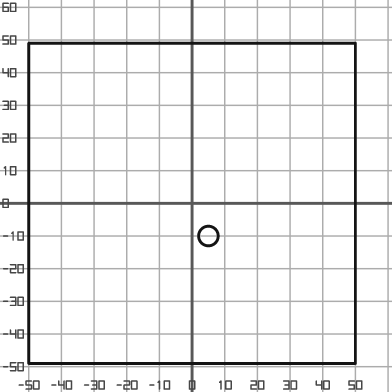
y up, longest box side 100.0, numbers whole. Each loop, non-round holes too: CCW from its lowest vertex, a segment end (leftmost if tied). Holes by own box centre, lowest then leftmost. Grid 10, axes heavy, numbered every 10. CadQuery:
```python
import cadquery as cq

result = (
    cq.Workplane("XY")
    .moveTo(-50.0, -49.0)
    .lineTo(50.0, -49.0)
    .lineTo(50.0, 49.0)
    .lineTo(-50.0, 49.0)
    .close()
    .moveTo(5.0, -10.0)
    .circle(3.0)
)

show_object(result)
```